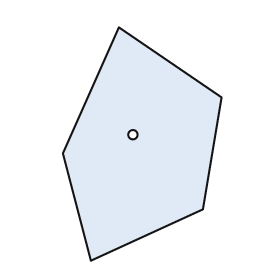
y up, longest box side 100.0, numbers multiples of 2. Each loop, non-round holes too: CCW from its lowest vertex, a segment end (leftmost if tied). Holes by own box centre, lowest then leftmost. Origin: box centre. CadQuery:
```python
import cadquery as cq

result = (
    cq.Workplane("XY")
    .moveTo(-22.0, -50.0)
    .lineTo(26.0, -28.0)
    .lineTo(34.0, 20.0)
    .lineTo(-10.0, 50.0)
    .lineTo(-34.0, -4.0)
    .close()
    .moveTo(-4.0, 4.0)
    .circle(2.0)
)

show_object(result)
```